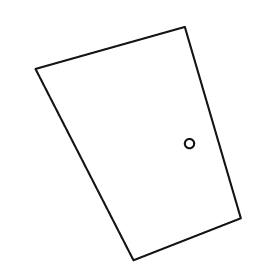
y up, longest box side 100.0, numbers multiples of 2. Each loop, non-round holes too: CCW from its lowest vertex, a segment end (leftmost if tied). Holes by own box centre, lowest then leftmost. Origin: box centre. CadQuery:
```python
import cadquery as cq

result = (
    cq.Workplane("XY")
    .moveTo(-2.0, -50.0)
    .lineTo(44.0, -32.0)
    .lineTo(20.0, 50.0)
    .lineTo(-44.0, 32.0)
    .close()
    .moveTo(22.0, 0.0)
    .circle(2.0)
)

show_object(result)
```